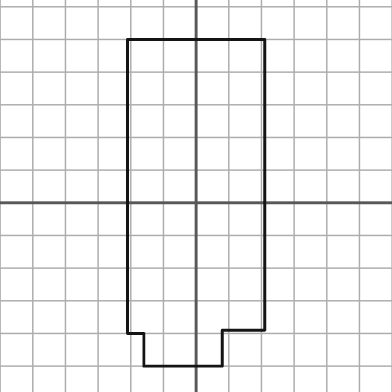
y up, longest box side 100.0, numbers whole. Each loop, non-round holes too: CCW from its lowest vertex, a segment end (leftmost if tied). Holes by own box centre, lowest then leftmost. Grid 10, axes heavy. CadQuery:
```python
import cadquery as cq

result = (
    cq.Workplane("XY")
    .moveTo(-16.0, -50.0)
    .lineTo(8.0, -50.0)
    .lineTo(8.0, -39.0)
    .lineTo(21.0, -39.0)
    .lineTo(21.0, 50.0)
    .lineTo(-21.0, 50.0)
    .lineTo(-21.0, -40.0)
    .lineTo(-16.0, -40.0)
    .close()
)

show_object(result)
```